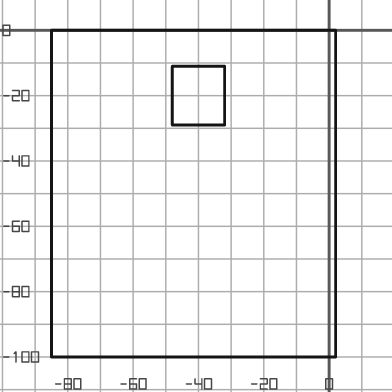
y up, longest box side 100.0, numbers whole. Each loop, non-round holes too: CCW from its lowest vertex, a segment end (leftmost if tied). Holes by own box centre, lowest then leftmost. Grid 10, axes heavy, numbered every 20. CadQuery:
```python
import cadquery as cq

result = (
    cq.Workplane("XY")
    .moveTo(-85.0, -100.0)
    .lineTo(2.0, -100.0)
    .lineTo(2.0, 0.0)
    .lineTo(-85.0, 0.0)
    .close()
    .moveTo(-48.0, -29.0)
    .lineTo(-32.0, -29.0)
    .lineTo(-32.0, -11.0)
    .lineTo(-48.0, -11.0)
    .close()
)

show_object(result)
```